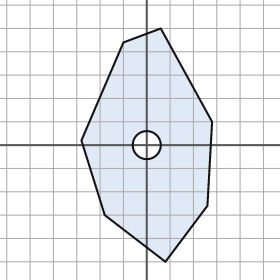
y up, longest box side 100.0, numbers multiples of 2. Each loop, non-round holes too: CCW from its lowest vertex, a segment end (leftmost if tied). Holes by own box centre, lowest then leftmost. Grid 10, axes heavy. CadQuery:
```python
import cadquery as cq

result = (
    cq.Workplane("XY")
    .moveTo(8.0, -50.0)
    .lineTo(26.0, -26.0)
    .lineTo(28.0, 10.0)
    .lineTo(6.0, 50.0)
    .lineTo(-10.0, 44.0)
    .lineTo(-28.0, 2.0)
    .lineTo(-18.0, -30.0)
    .close()
    .moveTo(0.0, 0.0)
    .circle(6.0)
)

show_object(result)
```